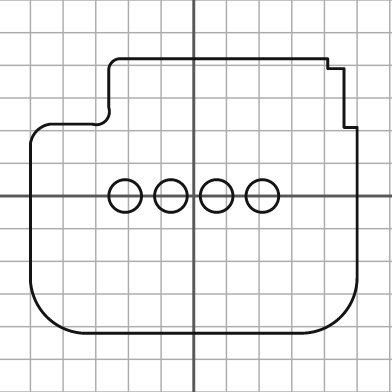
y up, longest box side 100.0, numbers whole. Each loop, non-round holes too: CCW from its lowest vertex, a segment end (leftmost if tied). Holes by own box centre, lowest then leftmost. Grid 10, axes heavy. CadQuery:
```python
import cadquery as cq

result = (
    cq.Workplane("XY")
    .moveTo(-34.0, -42.0)
    .lineTo(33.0, -42.0)
    .threePointArc((45.0, -37.0), (50.0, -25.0))
    .lineTo(50.0, 21.0)
    .lineTo(46.0, 21.0)
    .lineTo(46.0, 39.0)
    .lineTo(41.0, 39.0)
    .lineTo(41.0, 42.0)
    .lineTo(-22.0, 42.0)
    .threePointArc((-25.0, 41.0), (-26.0, 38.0))
    .lineTo(-26.0, 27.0)
    .threePointArc((-27.0, 23.0), (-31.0, 22.0))
    .lineTo(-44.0, 22.0)
    .threePointArc((-48.0, 20.0), (-50.0, 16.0))
    .lineTo(-50.0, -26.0)
    .threePointArc((-45.0, -37.0), (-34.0, -42.0))
    .close()
    .moveTo(-21.0, 0.0)
    .circle(5.0)
    .moveTo(-7.0, 0.0)
    .circle(5.0)
    .moveTo(7.0, 0.0)
    .circle(5.0)
    .moveTo(21.0, 0.0)
    .circle(5.0)
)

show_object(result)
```